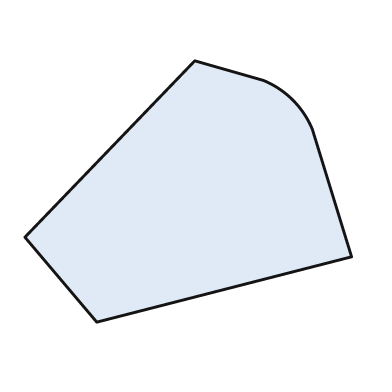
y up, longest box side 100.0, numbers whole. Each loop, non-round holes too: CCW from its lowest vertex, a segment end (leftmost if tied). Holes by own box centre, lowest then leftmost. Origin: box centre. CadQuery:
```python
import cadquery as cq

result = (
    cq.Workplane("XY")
    .moveTo(-28.0, -40.0)
    .lineTo(50.0, -20.0)
    .lineTo(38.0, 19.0)
    .threePointArc((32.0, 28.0), (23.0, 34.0))
    .lineTo(2.0, 40.0)
    .lineTo(-50.0, -14.0)
    .close()
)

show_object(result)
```